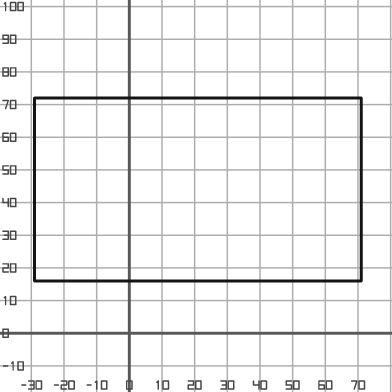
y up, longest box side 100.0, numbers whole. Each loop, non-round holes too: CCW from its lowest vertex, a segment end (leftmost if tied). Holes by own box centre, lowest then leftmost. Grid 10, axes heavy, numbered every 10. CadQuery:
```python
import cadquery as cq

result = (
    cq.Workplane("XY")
    .moveTo(-29.0, 16.0)
    .lineTo(71.0, 16.0)
    .lineTo(71.0, 72.0)
    .lineTo(-29.0, 72.0)
    .close()
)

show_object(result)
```